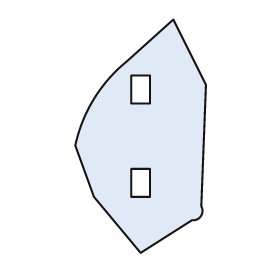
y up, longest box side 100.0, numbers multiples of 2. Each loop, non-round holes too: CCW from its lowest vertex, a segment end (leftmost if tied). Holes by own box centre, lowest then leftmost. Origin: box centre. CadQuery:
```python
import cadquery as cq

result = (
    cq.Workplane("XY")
    .moveTo(0.0, -50.0)
    .lineTo(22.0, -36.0)
    .threePointArc((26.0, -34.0), (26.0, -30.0))
    .lineTo(28.0, 22.0)
    .lineTo(14.0, 50.0)
    .lineTo(-6.0, 32.0)
    .threePointArc((-20.0, 16.0), (-28.0, -4.0))
    .lineTo(-20.0, -26.0)
    .close()
    .moveTo(-4.0, -26.0)
    .lineTo(4.0, -26.0)
    .lineTo(4.0, -14.0)
    .lineTo(-4.0, -14.0)
    .close()
    .moveTo(-4.0, 14.0)
    .lineTo(4.0, 14.0)
    .lineTo(4.0, 26.0)
    .lineTo(-4.0, 26.0)
    .close()
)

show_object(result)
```